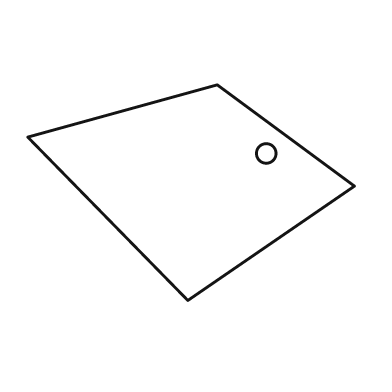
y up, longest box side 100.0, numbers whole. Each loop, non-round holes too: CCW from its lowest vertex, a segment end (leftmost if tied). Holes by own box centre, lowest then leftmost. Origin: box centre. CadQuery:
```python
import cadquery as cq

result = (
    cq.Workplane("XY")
    .moveTo(-1.0, -33.0)
    .lineTo(50.0, 2.0)
    .lineTo(8.0, 33.0)
    .lineTo(-50.0, 17.0)
    .close()
    .moveTo(23.0, 12.0)
    .circle(3.0)
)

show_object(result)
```